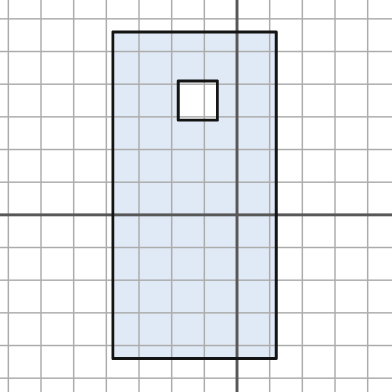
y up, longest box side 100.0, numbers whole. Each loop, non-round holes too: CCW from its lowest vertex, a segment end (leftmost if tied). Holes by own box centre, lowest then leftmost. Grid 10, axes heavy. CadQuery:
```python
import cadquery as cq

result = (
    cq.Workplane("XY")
    .moveTo(-38.0, -44.0)
    .lineTo(12.0, -44.0)
    .lineTo(12.0, 56.0)
    .lineTo(-38.0, 56.0)
    .close()
    .moveTo(-18.0, 29.0)
    .lineTo(-6.0, 29.0)
    .lineTo(-6.0, 41.0)
    .lineTo(-18.0, 41.0)
    .close()
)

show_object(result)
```